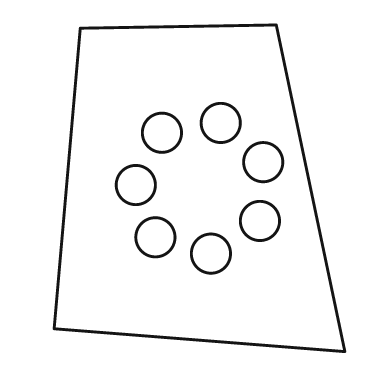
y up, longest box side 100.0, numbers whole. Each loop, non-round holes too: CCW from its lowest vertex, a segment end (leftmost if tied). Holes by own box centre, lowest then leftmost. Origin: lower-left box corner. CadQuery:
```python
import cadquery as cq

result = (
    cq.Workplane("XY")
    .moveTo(89.0, 0.0)
    .lineTo(68.0, 100.0)
    .lineTo(8.0, 99.0)
    .lineTo(0.0, 7.0)
    .close()
    .moveTo(48.0, 30.0)
    .circle(6.0)
    .moveTo(31.0, 35.0)
    .circle(6.0)
    .moveTo(63.0, 40.0)
    .circle(6.0)
    .moveTo(25.0, 51.0)
    .circle(6.0)
    .moveTo(64.0, 58.0)
    .circle(6.0)
    .moveTo(33.0, 67.0)
    .circle(6.0)
    .moveTo(51.0, 70.0)
    .circle(6.0)
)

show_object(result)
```